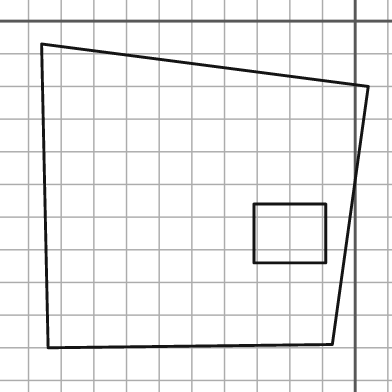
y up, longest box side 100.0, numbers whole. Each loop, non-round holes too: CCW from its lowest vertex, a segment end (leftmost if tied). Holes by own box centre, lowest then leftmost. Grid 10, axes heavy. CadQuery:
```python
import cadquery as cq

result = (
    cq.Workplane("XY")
    .moveTo(-94.0, -100.0)
    .lineTo(-7.0, -99.0)
    .lineTo(4.0, -20.0)
    .lineTo(-96.0, -7.0)
    .close()
    .moveTo(-31.0, -74.0)
    .lineTo(-9.0, -74.0)
    .lineTo(-9.0, -56.0)
    .lineTo(-31.0, -56.0)
    .close()
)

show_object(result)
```